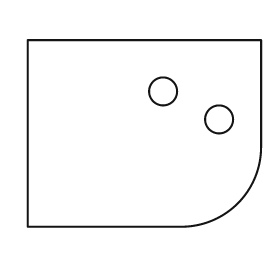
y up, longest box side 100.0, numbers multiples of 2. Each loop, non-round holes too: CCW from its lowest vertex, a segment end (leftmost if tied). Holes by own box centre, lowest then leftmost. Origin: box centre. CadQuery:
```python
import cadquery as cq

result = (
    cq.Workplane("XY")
    .moveTo(-50.0, -40.0)
    .lineTo(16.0, -40.0)
    .threePointArc((40.0, -30.0), (50.0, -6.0))
    .lineTo(50.0, 40.0)
    .lineTo(-50.0, 40.0)
    .close()
    .moveTo(32.0, 6.0)
    .circle(6.0)
    .moveTo(8.0, 18.0)
    .circle(6.0)
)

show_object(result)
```